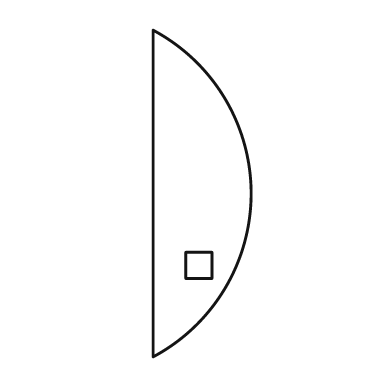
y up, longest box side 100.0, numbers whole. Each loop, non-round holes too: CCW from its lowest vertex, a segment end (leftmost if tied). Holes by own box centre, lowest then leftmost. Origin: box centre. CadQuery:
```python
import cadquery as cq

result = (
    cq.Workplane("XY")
    .moveTo(-15.0, -50.0)
    .threePointArc((15.0, 0.0), (-15.0, 50.0))
    .close()
    .moveTo(-5.0, -26.0)
    .lineTo(3.0, -26.0)
    .lineTo(3.0, -18.0)
    .lineTo(-5.0, -18.0)
    .close()
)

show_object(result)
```